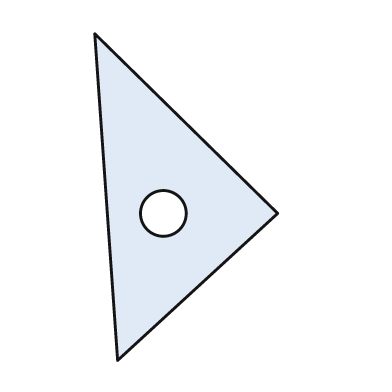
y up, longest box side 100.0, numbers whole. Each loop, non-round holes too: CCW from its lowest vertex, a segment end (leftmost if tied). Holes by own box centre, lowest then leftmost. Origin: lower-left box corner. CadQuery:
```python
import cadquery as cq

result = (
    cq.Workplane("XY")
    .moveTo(7.0, 0.0)
    .lineTo(56.0, 45.0)
    .lineTo(0.0, 100.0)
    .close()
    .moveTo(21.0, 45.0)
    .circle(7.0)
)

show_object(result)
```